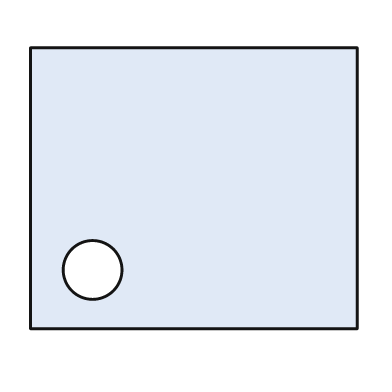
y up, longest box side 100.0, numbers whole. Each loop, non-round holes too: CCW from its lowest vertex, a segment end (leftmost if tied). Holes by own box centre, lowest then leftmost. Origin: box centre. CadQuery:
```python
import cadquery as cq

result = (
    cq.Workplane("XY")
    .moveTo(-50.0, -43.0)
    .lineTo(50.0, -43.0)
    .lineTo(50.0, 43.0)
    .lineTo(-50.0, 43.0)
    .close()
    .moveTo(-31.0, -25.0)
    .circle(9.0)
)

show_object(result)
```